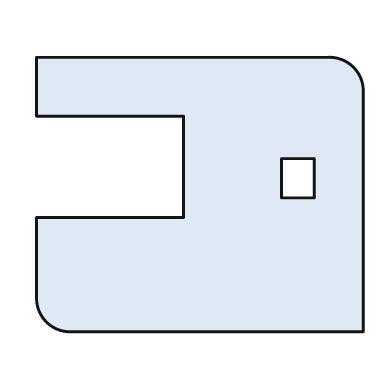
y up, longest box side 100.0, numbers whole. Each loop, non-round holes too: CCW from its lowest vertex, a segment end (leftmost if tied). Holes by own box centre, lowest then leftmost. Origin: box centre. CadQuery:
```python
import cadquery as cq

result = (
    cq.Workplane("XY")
    .moveTo(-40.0, -42.0)
    .lineTo(50.0, -42.0)
    .lineTo(50.0, 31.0)
    .threePointArc((47.0, 39.0), (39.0, 42.0))
    .lineTo(-50.0, 42.0)
    .lineTo(-50.0, 24.0)
    .lineTo(-5.0, 24.0)
    .lineTo(-5.0, -7.0)
    .lineTo(-50.0, -7.0)
    .lineTo(-50.0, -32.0)
    .threePointArc((-47.0, -39.0), (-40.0, -42.0))
    .close()
    .moveTo(25.0, -1.0)
    .lineTo(35.0, -1.0)
    .lineTo(35.0, 11.0)
    .lineTo(25.0, 11.0)
    .close()
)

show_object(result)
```